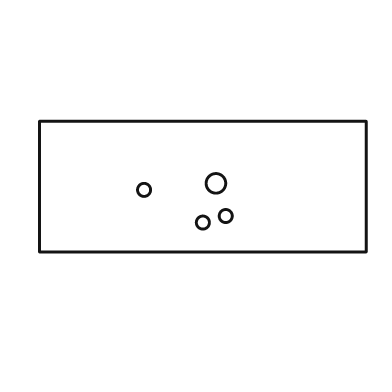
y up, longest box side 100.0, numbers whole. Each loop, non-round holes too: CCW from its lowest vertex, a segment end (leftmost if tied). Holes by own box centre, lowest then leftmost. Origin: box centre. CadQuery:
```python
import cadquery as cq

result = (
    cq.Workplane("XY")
    .moveTo(-50.0, -20.0)
    .lineTo(50.0, -20.0)
    .lineTo(50.0, 20.0)
    .lineTo(-50.0, 20.0)
    .close()
    .moveTo(0.0, -11.0)
    .circle(2.0)
    .moveTo(7.0, -9.0)
    .circle(2.0)
    .moveTo(-18.0, -1.0)
    .circle(2.0)
    .moveTo(4.0, 1.0)
    .circle(3.0)
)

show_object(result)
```